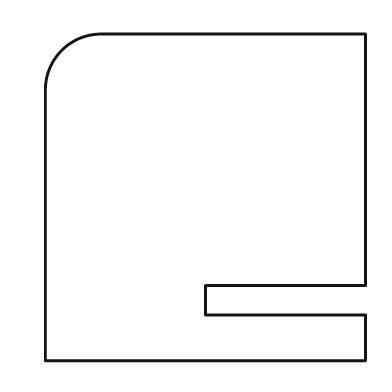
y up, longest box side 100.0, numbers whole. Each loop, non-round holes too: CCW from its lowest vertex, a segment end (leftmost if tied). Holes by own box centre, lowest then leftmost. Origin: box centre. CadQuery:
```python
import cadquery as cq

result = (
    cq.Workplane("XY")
    .moveTo(-49.0, -50.0)
    .lineTo(49.0, -50.0)
    .lineTo(49.0, -36.0)
    .lineTo(0.0, -36.0)
    .lineTo(0.0, -27.0)
    .lineTo(49.0, -27.0)
    .lineTo(49.0, 50.0)
    .lineTo(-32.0, 50.0)
    .threePointArc((-44.0, 45.0), (-49.0, 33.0))
    .close()
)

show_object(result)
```